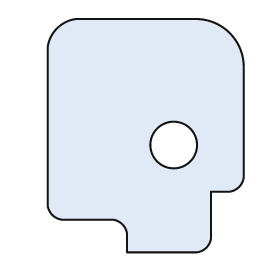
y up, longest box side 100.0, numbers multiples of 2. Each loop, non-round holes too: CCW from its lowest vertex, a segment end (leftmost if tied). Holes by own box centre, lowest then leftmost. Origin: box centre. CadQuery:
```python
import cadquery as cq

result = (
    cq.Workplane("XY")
    .moveTo(-8.0, -50.0)
    .lineTo(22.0, -50.0)
    .threePointArc((26.0, -48.0), (28.0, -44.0))
    .lineTo(28.0, -24.0)
    .lineTo(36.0, -24.0)
    .threePointArc((40.0, -22.0), (42.0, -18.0))
    .lineTo(42.0, 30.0)
    .threePointArc((36.0, 44.0), (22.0, 50.0))
    .lineTo(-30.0, 50.0)
    .threePointArc((-38.0, 46.0), (-42.0, 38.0))
    .lineTo(-42.0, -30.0)
    .threePointArc((-40.0, -34.0), (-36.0, -36.0))
    .lineTo(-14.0, -36.0)
    .threePointArc((-10.0, -38.0), (-8.0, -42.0))
    .close()
    .moveTo(12.0, -4.0)
    .circle(10.0)
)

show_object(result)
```